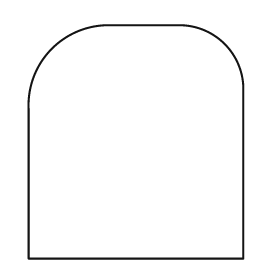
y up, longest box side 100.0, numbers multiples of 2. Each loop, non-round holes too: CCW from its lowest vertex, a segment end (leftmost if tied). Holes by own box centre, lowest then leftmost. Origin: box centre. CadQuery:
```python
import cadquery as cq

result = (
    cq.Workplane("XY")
    .moveTo(-46.0, -50.0)
    .lineTo(46.0, -50.0)
    .lineTo(46.0, 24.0)
    .threePointArc((38.0, 42.0), (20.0, 50.0))
    .lineTo(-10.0, 50.0)
    .threePointArc((-36.0, 40.0), (-46.0, 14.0))
    .close()
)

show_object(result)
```